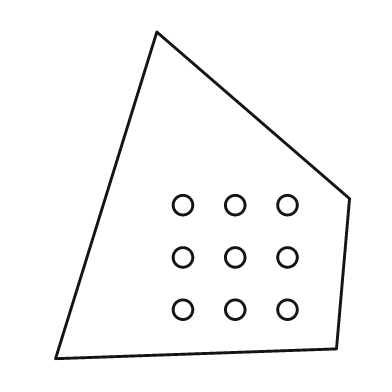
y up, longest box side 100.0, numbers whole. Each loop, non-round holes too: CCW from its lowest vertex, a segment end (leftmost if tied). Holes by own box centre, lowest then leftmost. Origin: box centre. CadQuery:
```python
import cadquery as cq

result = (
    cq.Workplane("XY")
    .moveTo(-45.0, -50.0)
    .lineTo(41.0, -47.0)
    .lineTo(45.0, -1.0)
    .lineTo(-14.0, 50.0)
    .close()
    .moveTo(-6.0, -35.0)
    .circle(3.0)
    .moveTo(10.0, -35.0)
    .circle(3.0)
    .moveTo(26.0, -35.0)
    .circle(3.0)
    .moveTo(-6.0, -19.0)
    .circle(3.0)
    .moveTo(10.0, -19.0)
    .circle(3.0)
    .moveTo(26.0, -19.0)
    .circle(3.0)
    .moveTo(-6.0, -3.0)
    .circle(3.0)
    .moveTo(10.0, -3.0)
    .circle(3.0)
    .moveTo(26.0, -3.0)
    .circle(3.0)
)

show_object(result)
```